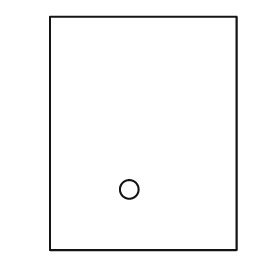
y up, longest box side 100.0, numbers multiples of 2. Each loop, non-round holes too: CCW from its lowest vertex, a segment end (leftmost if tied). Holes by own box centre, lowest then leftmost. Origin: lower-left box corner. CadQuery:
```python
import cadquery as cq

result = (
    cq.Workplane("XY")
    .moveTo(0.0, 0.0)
    .lineTo(80.0, 0.0)
    .lineTo(80.0, 100.0)
    .lineTo(0.0, 100.0)
    .close()
    .moveTo(34.0, 26.0)
    .circle(4.0)
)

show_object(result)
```